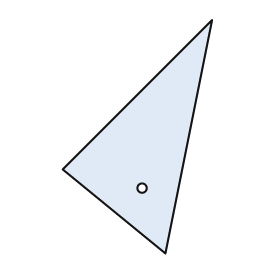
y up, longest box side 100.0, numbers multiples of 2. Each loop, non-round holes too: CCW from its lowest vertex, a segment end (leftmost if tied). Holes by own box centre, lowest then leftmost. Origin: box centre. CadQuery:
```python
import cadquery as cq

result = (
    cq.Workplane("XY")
    .moveTo(12.0, -50.0)
    .lineTo(32.0, 50.0)
    .lineTo(-32.0, -14.0)
    .close()
    .moveTo(2.0, -22.0)
    .circle(2.0)
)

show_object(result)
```